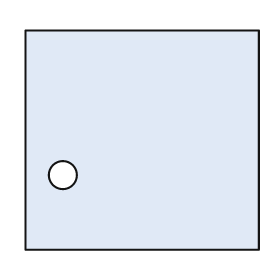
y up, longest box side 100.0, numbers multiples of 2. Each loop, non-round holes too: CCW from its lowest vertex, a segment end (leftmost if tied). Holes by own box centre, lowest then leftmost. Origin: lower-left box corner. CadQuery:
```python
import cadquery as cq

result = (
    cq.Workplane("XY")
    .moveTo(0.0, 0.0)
    .lineTo(100.0, 0.0)
    .lineTo(100.0, 94.0)
    .lineTo(0.0, 94.0)
    .close()
    .moveTo(16.0, 32.0)
    .circle(6.0)
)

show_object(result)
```